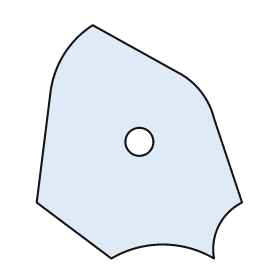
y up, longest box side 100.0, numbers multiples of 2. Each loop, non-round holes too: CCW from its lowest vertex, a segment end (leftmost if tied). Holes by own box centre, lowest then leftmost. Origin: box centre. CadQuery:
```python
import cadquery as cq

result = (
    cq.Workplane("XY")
    .moveTo(-12.0, -50.0)
    .threePointArc((10.0, -44.0), (32.0, -50.0))
    .threePointArc((34.0, -36.0), (44.0, -26.0))
    .lineTo(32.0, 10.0)
    .threePointArc((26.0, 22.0), (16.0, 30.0))
    .lineTo(-20.0, 50.0)
    .threePointArc((-32.0, 38.0), (-38.0, 22.0))
    .lineTo(-44.0, -26.0)
    .close()
    .moveTo(0.0, 0.0)
    .circle(6.0)
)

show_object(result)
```